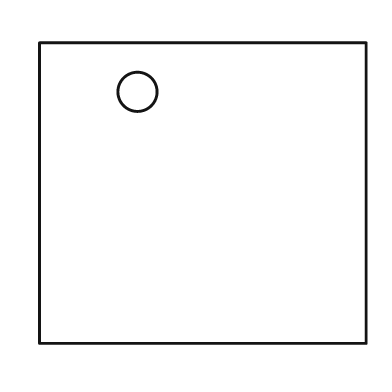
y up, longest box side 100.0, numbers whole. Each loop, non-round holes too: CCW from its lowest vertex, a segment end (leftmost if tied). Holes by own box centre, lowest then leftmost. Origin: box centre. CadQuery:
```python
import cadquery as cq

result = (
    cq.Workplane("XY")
    .moveTo(-50.0, -46.0)
    .lineTo(50.0, -46.0)
    .lineTo(50.0, 46.0)
    .lineTo(-50.0, 46.0)
    .close()
    .moveTo(-20.0, 31.0)
    .circle(6.0)
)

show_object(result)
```